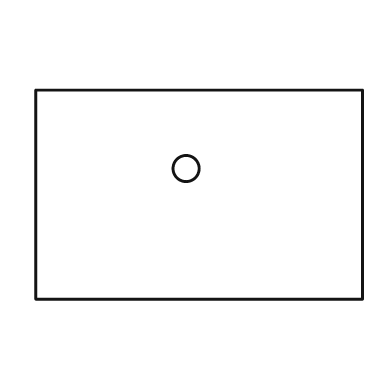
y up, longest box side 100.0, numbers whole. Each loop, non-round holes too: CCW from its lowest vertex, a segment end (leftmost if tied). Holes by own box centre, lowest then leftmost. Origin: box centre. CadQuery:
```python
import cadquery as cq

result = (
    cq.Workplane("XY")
    .moveTo(-50.0, -32.0)
    .lineTo(50.0, -32.0)
    .lineTo(50.0, 32.0)
    .lineTo(-50.0, 32.0)
    .close()
    .moveTo(-4.0, 8.0)
    .circle(4.0)
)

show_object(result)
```